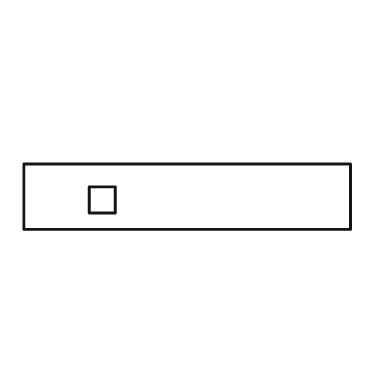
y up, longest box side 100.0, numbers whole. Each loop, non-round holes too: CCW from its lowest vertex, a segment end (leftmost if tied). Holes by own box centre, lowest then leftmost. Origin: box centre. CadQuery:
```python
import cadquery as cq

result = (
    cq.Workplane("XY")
    .moveTo(-50.0, -10.0)
    .lineTo(50.0, -10.0)
    .lineTo(50.0, 10.0)
    .lineTo(-50.0, 10.0)
    .close()
    .moveTo(-30.0, -5.0)
    .lineTo(-22.0, -5.0)
    .lineTo(-22.0, 3.0)
    .lineTo(-30.0, 3.0)
    .close()
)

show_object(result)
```